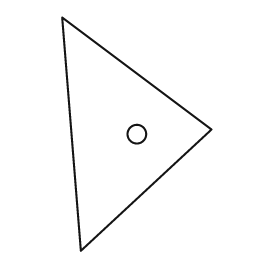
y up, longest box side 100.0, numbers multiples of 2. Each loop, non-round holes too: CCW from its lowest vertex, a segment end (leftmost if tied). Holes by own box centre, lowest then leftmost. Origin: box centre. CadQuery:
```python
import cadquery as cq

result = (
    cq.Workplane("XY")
    .moveTo(-24.0, -50.0)
    .lineTo(32.0, 2.0)
    .lineTo(-32.0, 50.0)
    .close()
    .moveTo(0.0, 0.0)
    .circle(4.0)
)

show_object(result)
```